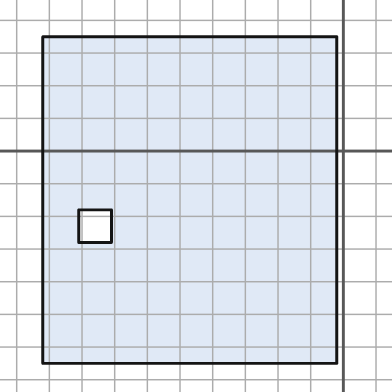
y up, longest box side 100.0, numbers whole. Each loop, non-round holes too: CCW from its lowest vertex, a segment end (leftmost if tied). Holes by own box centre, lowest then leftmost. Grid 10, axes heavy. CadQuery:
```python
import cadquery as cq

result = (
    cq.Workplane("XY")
    .moveTo(-92.0, -65.0)
    .lineTo(-2.0, -65.0)
    .lineTo(-2.0, 35.0)
    .lineTo(-92.0, 35.0)
    .close()
    .moveTo(-81.0, -28.0)
    .lineTo(-71.0, -28.0)
    .lineTo(-71.0, -18.0)
    .lineTo(-81.0, -18.0)
    .close()
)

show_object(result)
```